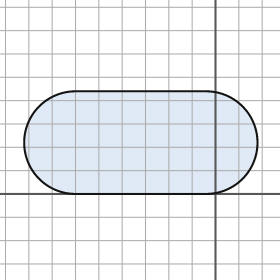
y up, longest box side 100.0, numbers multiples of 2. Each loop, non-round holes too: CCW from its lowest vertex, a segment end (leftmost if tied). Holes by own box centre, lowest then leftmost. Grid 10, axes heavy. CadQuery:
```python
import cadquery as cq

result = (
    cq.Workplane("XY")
    .moveTo(-60.0, 0.0)
    .lineTo(-4.0, 0.0)
    .threePointArc((18.0, 22.0), (-4.0, 44.0))
    .lineTo(-60.0, 44.0)
    .threePointArc((-82.0, 22.0), (-60.0, 0.0))
    .close()
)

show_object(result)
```